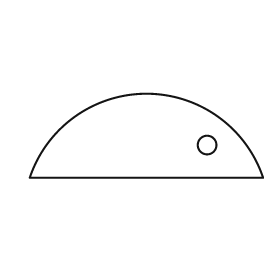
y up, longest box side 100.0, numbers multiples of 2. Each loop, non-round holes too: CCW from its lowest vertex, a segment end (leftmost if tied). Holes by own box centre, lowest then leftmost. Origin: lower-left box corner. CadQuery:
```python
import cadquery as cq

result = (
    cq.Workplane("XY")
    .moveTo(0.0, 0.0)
    .lineTo(100.0, 0.0)
    .threePointArc((50.0, 36.0), (0.0, 0.0))
    .close()
    .moveTo(76.0, 14.0)
    .circle(4.0)
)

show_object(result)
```